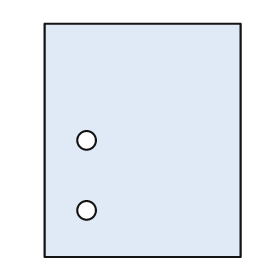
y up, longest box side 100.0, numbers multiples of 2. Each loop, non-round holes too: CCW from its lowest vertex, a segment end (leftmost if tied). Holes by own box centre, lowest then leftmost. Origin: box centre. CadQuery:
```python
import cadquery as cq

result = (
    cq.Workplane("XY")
    .moveTo(-42.0, -50.0)
    .lineTo(42.0, -50.0)
    .lineTo(42.0, 50.0)
    .lineTo(-42.0, 50.0)
    .close()
    .moveTo(-24.0, -30.0)
    .circle(4.0)
    .moveTo(-24.0, 0.0)
    .circle(4.0)
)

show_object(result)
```